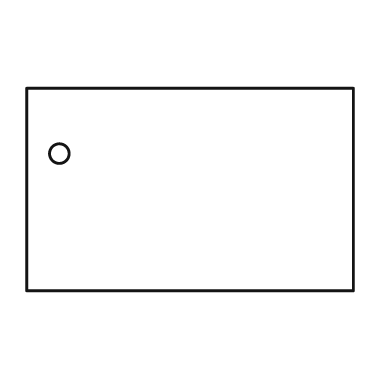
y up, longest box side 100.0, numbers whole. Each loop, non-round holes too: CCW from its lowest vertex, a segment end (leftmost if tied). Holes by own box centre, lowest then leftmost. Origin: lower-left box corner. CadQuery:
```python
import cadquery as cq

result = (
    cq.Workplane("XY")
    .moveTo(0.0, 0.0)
    .lineTo(100.0, 0.0)
    .lineTo(100.0, 62.0)
    .lineTo(0.0, 62.0)
    .close()
    .moveTo(10.0, 42.0)
    .circle(3.0)
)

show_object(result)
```